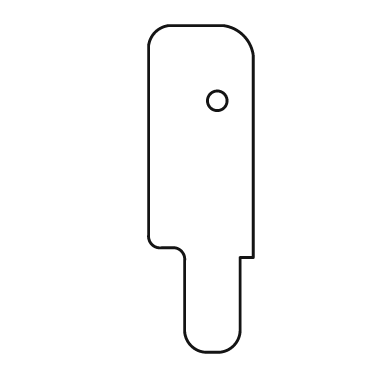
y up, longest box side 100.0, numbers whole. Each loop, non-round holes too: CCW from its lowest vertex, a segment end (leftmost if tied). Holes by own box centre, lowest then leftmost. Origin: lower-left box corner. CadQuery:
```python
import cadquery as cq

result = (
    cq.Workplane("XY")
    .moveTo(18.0, 0.0)
    .lineTo(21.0, 0.0)
    .threePointArc((26.0, 2.0), (28.0, 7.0))
    .lineTo(28.0, 29.0)
    .lineTo(32.0, 29.0)
    .lineTo(32.0, 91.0)
    .threePointArc((29.0, 97.0), (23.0, 100.0))
    .lineTo(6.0, 100.0)
    .threePointArc((2.0, 98.0), (0.0, 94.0))
    .lineTo(0.0, 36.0)
    .threePointArc((1.0, 33.0), (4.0, 32.0))
    .lineTo(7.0, 32.0)
    .threePointArc((10.0, 31.0), (11.0, 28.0))
    .lineTo(11.0, 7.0)
    .threePointArc((13.0, 2.0), (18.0, 0.0))
    .close()
    .moveTo(21.0, 77.0)
    .circle(3.0)
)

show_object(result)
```